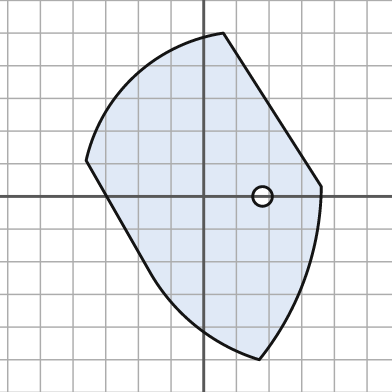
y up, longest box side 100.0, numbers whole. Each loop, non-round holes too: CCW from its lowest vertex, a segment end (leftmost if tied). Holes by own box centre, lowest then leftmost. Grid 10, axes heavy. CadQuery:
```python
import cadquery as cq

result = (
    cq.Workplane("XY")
    .moveTo(17.0, -50.0)
    .threePointArc((31.0, -25.0), (36.0, 3.0))
    .lineTo(6.0, 50.0)
    .threePointArc((-21.0, 37.0), (-36.0, 11.0))
    .lineTo(-16.0, -24.0)
    .threePointArc((-2.0, -40.0), (17.0, -50.0))
    .close()
    .moveTo(18.0, 0.0)
    .circle(3.0)
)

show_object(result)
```